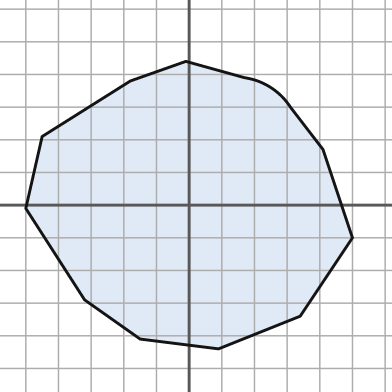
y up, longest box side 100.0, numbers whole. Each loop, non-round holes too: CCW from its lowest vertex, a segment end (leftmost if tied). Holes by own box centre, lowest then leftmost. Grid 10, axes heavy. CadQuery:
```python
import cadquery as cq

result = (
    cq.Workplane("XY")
    .moveTo(9.0, -44.0)
    .lineTo(34.0, -34.0)
    .lineTo(50.0, -10.0)
    .lineTo(41.0, 17.0)
    .lineTo(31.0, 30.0)
    .threePointArc((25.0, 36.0), (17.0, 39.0))
    .lineTo(-1.0, 44.0)
    .lineTo(-18.0, 38.0)
    .lineTo(-45.0, 21.0)
    .lineTo(-50.0, -1.0)
    .lineTo(-32.0, -29.0)
    .lineTo(-15.0, -41.0)
    .close()
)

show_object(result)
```